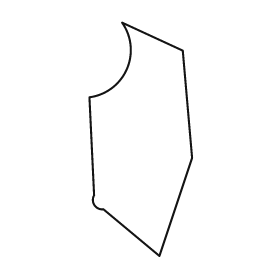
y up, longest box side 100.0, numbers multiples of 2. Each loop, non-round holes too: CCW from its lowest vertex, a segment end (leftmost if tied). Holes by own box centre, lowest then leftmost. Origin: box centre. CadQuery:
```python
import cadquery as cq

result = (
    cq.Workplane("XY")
    .moveTo(8.0, -50.0)
    .lineTo(22.0, -8.0)
    .lineTo(18.0, 38.0)
    .lineTo(-8.0, 50.0)
    .threePointArc((-6.0, 30.0), (-22.0, 18.0))
    .lineTo(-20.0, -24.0)
    .threePointArc((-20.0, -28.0), (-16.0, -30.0))
    .close()
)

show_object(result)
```